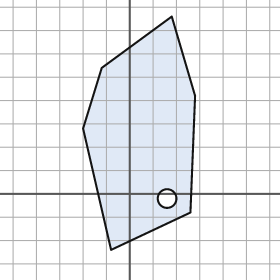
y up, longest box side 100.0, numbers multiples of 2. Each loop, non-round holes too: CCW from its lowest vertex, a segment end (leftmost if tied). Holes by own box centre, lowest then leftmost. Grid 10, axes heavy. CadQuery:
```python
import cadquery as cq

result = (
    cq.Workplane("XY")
    .moveTo(-8.0, -24.0)
    .lineTo(26.0, -8.0)
    .lineTo(28.0, 42.0)
    .lineTo(18.0, 76.0)
    .lineTo(-12.0, 54.0)
    .lineTo(-20.0, 28.0)
    .close()
    .moveTo(16.0, -2.0)
    .circle(4.0)
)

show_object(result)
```